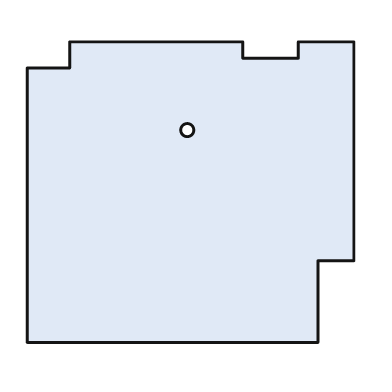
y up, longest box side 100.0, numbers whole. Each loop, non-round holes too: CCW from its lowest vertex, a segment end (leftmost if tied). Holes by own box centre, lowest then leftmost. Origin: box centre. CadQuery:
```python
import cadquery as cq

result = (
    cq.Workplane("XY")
    .moveTo(-50.0, -46.0)
    .lineTo(39.0, -46.0)
    .lineTo(39.0, -21.0)
    .lineTo(50.0, -21.0)
    .lineTo(50.0, 46.0)
    .lineTo(33.0, 46.0)
    .lineTo(33.0, 41.0)
    .lineTo(16.0, 41.0)
    .lineTo(16.0, 46.0)
    .lineTo(-37.0, 46.0)
    .lineTo(-37.0, 38.0)
    .lineTo(-50.0, 38.0)
    .close()
    .moveTo(-1.0, 19.0)
    .circle(2.0)
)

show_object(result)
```